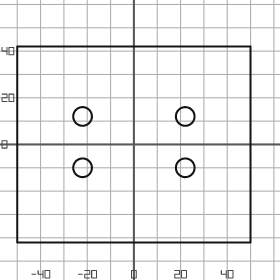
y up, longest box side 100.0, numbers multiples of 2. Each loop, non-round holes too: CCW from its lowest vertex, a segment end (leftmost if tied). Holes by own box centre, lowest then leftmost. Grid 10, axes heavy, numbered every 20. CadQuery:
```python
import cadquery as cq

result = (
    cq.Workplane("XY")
    .moveTo(-50.0, -42.0)
    .lineTo(50.0, -42.0)
    .lineTo(50.0, 42.0)
    .lineTo(-50.0, 42.0)
    .close()
    .moveTo(-22.0, -10.0)
    .circle(4.0)
    .moveTo(22.0, -10.0)
    .circle(4.0)
    .moveTo(-22.0, 12.0)
    .circle(4.0)
    .moveTo(22.0, 12.0)
    .circle(4.0)
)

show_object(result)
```